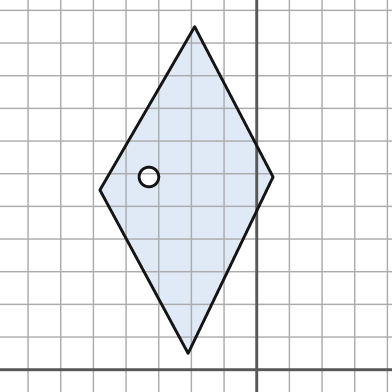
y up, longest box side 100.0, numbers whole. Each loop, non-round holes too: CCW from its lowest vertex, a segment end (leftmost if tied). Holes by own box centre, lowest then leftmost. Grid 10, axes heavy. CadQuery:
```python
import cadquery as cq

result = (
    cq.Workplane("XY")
    .moveTo(-21.0, 5.0)
    .lineTo(5.0, 59.0)
    .lineTo(-19.0, 105.0)
    .lineTo(-48.0, 55.0)
    .close()
    .moveTo(-33.0, 59.0)
    .circle(3.0)
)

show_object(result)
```